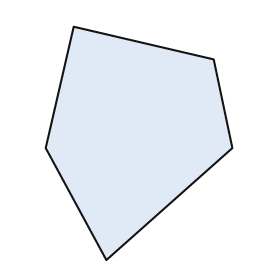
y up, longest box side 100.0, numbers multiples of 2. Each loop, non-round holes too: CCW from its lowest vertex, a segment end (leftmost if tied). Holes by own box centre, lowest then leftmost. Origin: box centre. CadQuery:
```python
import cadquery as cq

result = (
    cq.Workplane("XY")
    .moveTo(-14.0, -50.0)
    .lineTo(40.0, -2.0)
    .lineTo(32.0, 36.0)
    .lineTo(-28.0, 50.0)
    .lineTo(-40.0, -2.0)
    .close()
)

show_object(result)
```